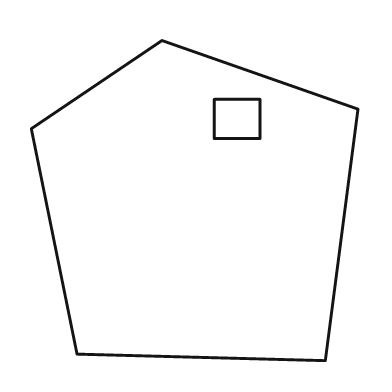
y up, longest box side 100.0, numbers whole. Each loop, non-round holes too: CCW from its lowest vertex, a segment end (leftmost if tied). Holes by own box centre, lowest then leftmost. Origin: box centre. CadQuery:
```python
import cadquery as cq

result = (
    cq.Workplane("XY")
    .moveTo(40.0, -49.0)
    .lineTo(50.0, 28.0)
    .lineTo(-10.0, 49.0)
    .lineTo(-50.0, 22.0)
    .lineTo(-36.0, -47.0)
    .close()
    .moveTo(6.0, 19.0)
    .lineTo(20.0, 19.0)
    .lineTo(20.0, 31.0)
    .lineTo(6.0, 31.0)
    .close()
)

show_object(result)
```